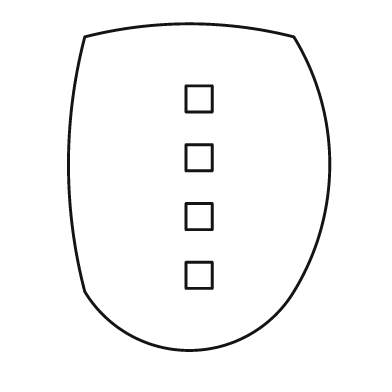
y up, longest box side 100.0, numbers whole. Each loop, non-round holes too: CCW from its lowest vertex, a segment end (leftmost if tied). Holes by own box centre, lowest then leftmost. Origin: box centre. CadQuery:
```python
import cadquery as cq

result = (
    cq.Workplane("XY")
    .moveTo(-35.0, -32.0)
    .threePointArc((-3.0, -50.0), (29.0, -32.0))
    .threePointArc((40.0, 7.0), (29.0, 46.0))
    .threePointArc((-3.0, 50.0), (-35.0, 46.0))
    .threePointArc((-40.0, 7.0), (-35.0, -32.0))
    .close()
    .moveTo(-4.0, -31.0)
    .lineTo(4.0, -31.0)
    .lineTo(4.0, -23.0)
    .lineTo(-4.0, -23.0)
    .close()
    .moveTo(-4.0, -13.0)
    .lineTo(4.0, -13.0)
    .lineTo(4.0, -5.0)
    .lineTo(-4.0, -5.0)
    .close()
    .moveTo(-4.0, 5.0)
    .lineTo(4.0, 5.0)
    .lineTo(4.0, 13.0)
    .lineTo(-4.0, 13.0)
    .close()
    .moveTo(-4.0, 23.0)
    .lineTo(4.0, 23.0)
    .lineTo(4.0, 31.0)
    .lineTo(-4.0, 31.0)
    .close()
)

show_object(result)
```